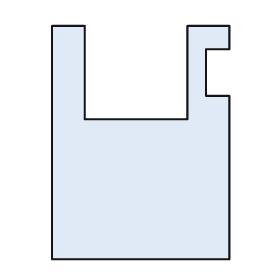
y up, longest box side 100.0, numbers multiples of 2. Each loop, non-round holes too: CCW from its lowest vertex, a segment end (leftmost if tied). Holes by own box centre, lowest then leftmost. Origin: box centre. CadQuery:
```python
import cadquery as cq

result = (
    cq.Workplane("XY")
    .moveTo(-38.0, -50.0)
    .lineTo(38.0, -50.0)
    .lineTo(38.0, 20.0)
    .lineTo(28.0, 20.0)
    .lineTo(28.0, 40.0)
    .lineTo(38.0, 40.0)
    .lineTo(38.0, 50.0)
    .lineTo(20.0, 50.0)
    .lineTo(20.0, 10.0)
    .lineTo(-24.0, 10.0)
    .lineTo(-24.0, 50.0)
    .lineTo(-38.0, 50.0)
    .close()
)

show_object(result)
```